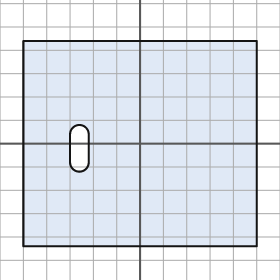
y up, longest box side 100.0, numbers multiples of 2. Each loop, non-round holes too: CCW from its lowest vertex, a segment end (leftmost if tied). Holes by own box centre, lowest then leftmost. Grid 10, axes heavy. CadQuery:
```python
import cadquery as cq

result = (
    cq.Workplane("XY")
    .moveTo(-50.0, -44.0)
    .lineTo(50.0, -44.0)
    .lineTo(50.0, 44.0)
    .lineTo(-50.0, 44.0)
    .close()
    .moveTo(-30.0, -8.0)
    .threePointArc((-26.0, -12.0), (-22.0, -8.0))
    .lineTo(-22.0, 4.0)
    .threePointArc((-26.0, 8.0), (-30.0, 4.0))
    .close()
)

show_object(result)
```